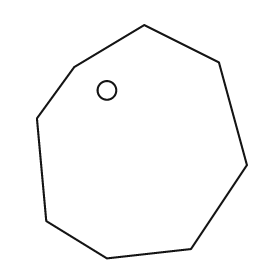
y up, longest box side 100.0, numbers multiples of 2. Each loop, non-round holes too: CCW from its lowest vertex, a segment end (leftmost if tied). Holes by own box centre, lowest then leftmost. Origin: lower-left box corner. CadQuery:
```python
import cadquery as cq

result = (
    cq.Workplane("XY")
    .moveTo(30.0, 0.0)
    .lineTo(66.0, 4.0)
    .lineTo(90.0, 40.0)
    .lineTo(78.0, 84.0)
    .lineTo(46.0, 100.0)
    .lineTo(16.0, 82.0)
    .lineTo(0.0, 60.0)
    .lineTo(4.0, 16.0)
    .close()
    .moveTo(30.0, 72.0)
    .circle(4.0)
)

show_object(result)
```